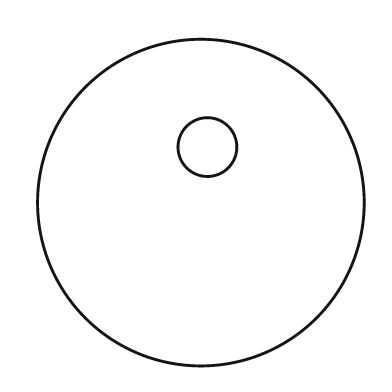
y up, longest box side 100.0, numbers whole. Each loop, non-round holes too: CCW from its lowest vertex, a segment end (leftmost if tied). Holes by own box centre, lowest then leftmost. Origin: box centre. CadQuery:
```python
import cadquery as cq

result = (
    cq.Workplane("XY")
    .moveTo(0.0, 0.0)
    .circle(50.0)
    .moveTo(2.0, 17.0)
    .circle(9.0)
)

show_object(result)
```